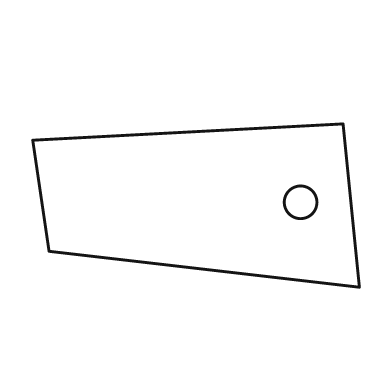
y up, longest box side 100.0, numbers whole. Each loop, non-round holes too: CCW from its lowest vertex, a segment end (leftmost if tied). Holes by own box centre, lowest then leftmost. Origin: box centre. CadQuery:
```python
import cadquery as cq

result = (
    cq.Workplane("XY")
    .moveTo(50.0, -25.0)
    .lineTo(45.0, 25.0)
    .lineTo(-50.0, 20.0)
    .lineTo(-45.0, -14.0)
    .close()
    .moveTo(32.0, 1.0)
    .circle(5.0)
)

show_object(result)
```